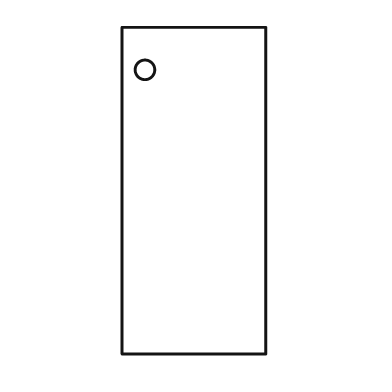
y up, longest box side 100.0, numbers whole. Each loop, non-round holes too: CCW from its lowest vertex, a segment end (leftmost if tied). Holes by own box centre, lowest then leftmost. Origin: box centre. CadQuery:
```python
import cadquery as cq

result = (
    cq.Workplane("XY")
    .moveTo(-22.0, -50.0)
    .lineTo(22.0, -50.0)
    .lineTo(22.0, 50.0)
    .lineTo(-22.0, 50.0)
    .close()
    .moveTo(-15.0, 37.0)
    .circle(3.0)
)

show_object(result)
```